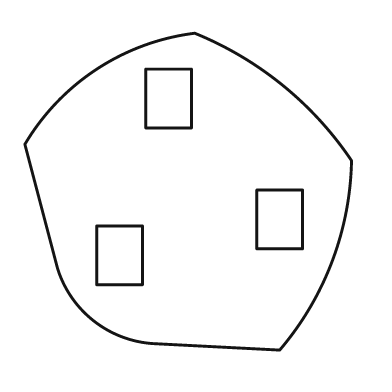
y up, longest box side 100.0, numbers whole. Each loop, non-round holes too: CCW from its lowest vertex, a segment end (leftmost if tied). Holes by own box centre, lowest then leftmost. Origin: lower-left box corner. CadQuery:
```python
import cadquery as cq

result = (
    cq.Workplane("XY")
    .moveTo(78.0, 0.0)
    .threePointArc((94.0, 27.0), (100.0, 58.0))
    .threePointArc((79.0, 81.0), (52.0, 97.0))
    .threePointArc((22.0, 86.0), (0.0, 63.0))
    .lineTo(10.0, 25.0)
    .threePointArc((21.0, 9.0), (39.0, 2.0))
    .close()
    .moveTo(22.0, 20.0)
    .lineTo(36.0, 20.0)
    .lineTo(36.0, 38.0)
    .lineTo(22.0, 38.0)
    .close()
    .moveTo(71.0, 31.0)
    .lineTo(85.0, 31.0)
    .lineTo(85.0, 49.0)
    .lineTo(71.0, 49.0)
    .close()
    .moveTo(37.0, 68.0)
    .lineTo(51.0, 68.0)
    .lineTo(51.0, 86.0)
    .lineTo(37.0, 86.0)
    .close()
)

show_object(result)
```